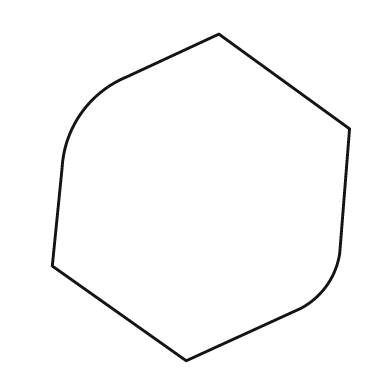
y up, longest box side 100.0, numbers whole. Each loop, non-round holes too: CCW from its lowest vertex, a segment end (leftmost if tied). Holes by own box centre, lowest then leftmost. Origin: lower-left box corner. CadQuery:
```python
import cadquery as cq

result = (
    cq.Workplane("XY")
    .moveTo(41.0, 0.0)
    .lineTo(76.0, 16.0)
    .threePointArc((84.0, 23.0), (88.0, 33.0))
    .lineTo(91.0, 71.0)
    .lineTo(51.0, 100.0)
    .lineTo(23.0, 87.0)
    .threePointArc((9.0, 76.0), (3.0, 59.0))
    .lineTo(0.0, 29.0)
    .close()
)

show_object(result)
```